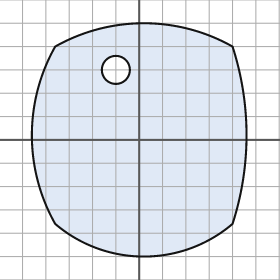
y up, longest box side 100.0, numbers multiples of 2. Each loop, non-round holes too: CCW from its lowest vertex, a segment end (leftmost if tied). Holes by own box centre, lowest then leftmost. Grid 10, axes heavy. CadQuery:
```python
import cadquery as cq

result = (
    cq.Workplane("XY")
    .moveTo(-36.0, -36.0)
    .threePointArc((2.0, -50.0), (40.0, -36.0))
    .threePointArc((46.0, 2.0), (40.0, 40.0))
    .threePointArc((2.0, 50.0), (-36.0, 40.0))
    .threePointArc((-46.0, 2.0), (-36.0, -36.0))
    .close()
    .moveTo(-10.0, 30.0)
    .circle(6.0)
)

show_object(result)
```